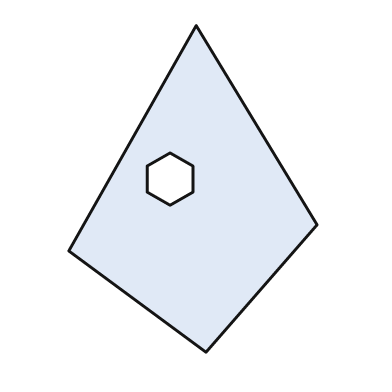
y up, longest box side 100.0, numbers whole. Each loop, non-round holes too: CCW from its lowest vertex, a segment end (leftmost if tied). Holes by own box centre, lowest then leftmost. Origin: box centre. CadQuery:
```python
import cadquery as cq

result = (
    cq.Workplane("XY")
    .moveTo(4.0, -50.0)
    .lineTo(38.0, -11.0)
    .lineTo(1.0, 50.0)
    .lineTo(-38.0, -19.0)
    .close()
    .moveTo(-7.0, -5.0)
    .lineTo(0.0, -1.0)
    .lineTo(0.0, 7.0)
    .lineTo(-7.0, 11.0)
    .lineTo(-14.0, 7.0)
    .lineTo(-14.0, -1.0)
    .close()
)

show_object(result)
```